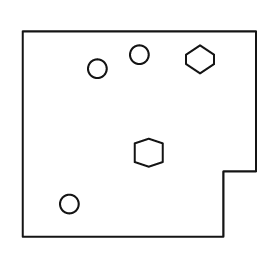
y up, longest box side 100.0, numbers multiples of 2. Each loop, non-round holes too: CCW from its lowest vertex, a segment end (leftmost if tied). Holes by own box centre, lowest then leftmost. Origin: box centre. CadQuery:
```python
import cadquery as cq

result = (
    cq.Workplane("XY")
    .moveTo(-50.0, -44.0)
    .lineTo(36.0, -44.0)
    .lineTo(36.0, -16.0)
    .lineTo(50.0, -16.0)
    .lineTo(50.0, 44.0)
    .lineTo(-50.0, 44.0)
    .close()
    .moveTo(-30.0, -30.0)
    .circle(4.0)
    .moveTo(4.0, -14.0)
    .lineTo(10.0, -12.0)
    .lineTo(10.0, -4.0)
    .lineTo(4.0, -2.0)
    .lineTo(-2.0, -4.0)
    .lineTo(-2.0, -12.0)
    .close()
    .moveTo(-18.0, 28.0)
    .circle(4.0)
    .moveTo(26.0, 26.0)
    .lineTo(32.0, 30.0)
    .lineTo(32.0, 34.0)
    .lineTo(26.0, 38.0)
    .lineTo(20.0, 34.0)
    .lineTo(20.0, 30.0)
    .close()
    .moveTo(0.0, 34.0)
    .circle(4.0)
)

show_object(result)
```